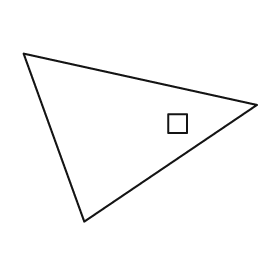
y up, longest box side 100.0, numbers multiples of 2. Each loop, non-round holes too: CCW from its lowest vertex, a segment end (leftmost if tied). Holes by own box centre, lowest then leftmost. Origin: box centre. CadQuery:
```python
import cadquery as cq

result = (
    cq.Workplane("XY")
    .moveTo(-24.0, -36.0)
    .lineTo(50.0, 14.0)
    .lineTo(-50.0, 36.0)
    .close()
    .moveTo(12.0, 2.0)
    .lineTo(20.0, 2.0)
    .lineTo(20.0, 10.0)
    .lineTo(12.0, 10.0)
    .close()
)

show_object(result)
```